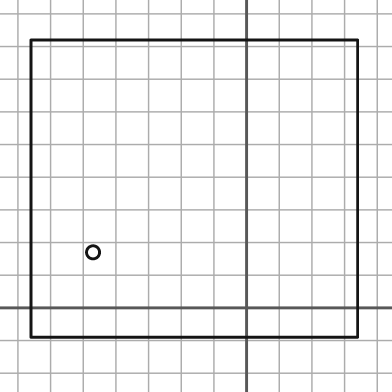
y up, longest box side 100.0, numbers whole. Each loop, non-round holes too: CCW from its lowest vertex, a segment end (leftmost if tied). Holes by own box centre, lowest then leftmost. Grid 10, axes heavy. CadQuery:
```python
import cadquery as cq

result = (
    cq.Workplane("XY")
    .moveTo(-66.0, -9.0)
    .lineTo(34.0, -9.0)
    .lineTo(34.0, 82.0)
    .lineTo(-66.0, 82.0)
    .close()
    .moveTo(-47.0, 17.0)
    .circle(2.0)
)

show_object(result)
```